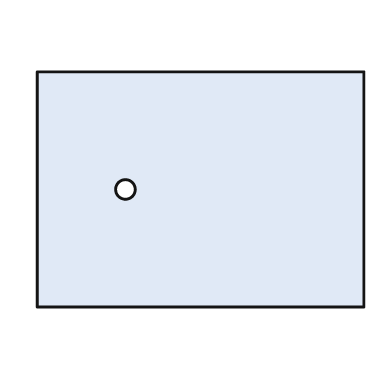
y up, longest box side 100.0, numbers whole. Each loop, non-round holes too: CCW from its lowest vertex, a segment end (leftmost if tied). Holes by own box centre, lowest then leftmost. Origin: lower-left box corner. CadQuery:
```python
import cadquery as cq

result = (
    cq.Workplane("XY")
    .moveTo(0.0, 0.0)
    .lineTo(100.0, 0.0)
    .lineTo(100.0, 72.0)
    .lineTo(0.0, 72.0)
    .close()
    .moveTo(27.0, 36.0)
    .circle(3.0)
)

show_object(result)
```